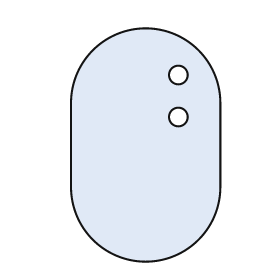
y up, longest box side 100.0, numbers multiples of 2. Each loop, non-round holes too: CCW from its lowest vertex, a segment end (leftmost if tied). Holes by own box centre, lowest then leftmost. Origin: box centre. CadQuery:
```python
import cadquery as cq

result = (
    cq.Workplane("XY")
    .moveTo(-32.0, -18.0)
    .threePointArc((0.0, -50.0), (32.0, -18.0))
    .lineTo(32.0, 18.0)
    .threePointArc((0.0, 50.0), (-32.0, 18.0))
    .close()
    .moveTo(14.0, 12.0)
    .circle(4.0)
    .moveTo(14.0, 30.0)
    .circle(4.0)
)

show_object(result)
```